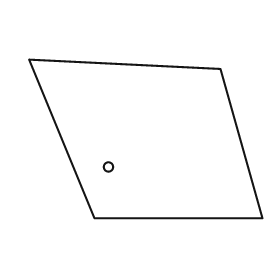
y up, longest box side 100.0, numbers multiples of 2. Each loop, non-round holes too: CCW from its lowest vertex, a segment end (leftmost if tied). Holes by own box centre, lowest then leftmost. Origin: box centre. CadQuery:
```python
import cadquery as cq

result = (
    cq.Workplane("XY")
    .moveTo(-22.0, -34.0)
    .lineTo(50.0, -34.0)
    .lineTo(32.0, 30.0)
    .lineTo(-50.0, 34.0)
    .close()
    .moveTo(-16.0, -12.0)
    .circle(2.0)
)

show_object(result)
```